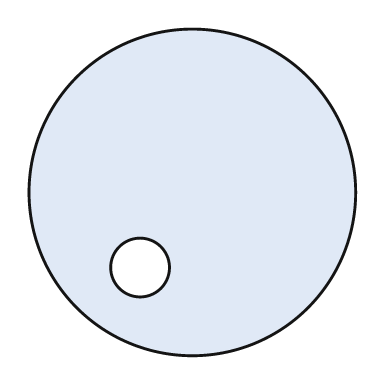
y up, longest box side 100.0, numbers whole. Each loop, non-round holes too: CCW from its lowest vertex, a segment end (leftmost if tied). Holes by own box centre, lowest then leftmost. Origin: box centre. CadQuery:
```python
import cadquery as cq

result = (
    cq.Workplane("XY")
    .moveTo(0.0, 0.0)
    .circle(50.0)
    .moveTo(-16.0, -23.0)
    .circle(9.0)
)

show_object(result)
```